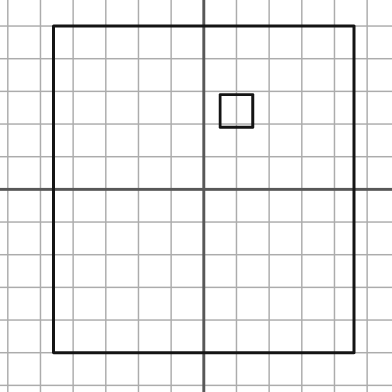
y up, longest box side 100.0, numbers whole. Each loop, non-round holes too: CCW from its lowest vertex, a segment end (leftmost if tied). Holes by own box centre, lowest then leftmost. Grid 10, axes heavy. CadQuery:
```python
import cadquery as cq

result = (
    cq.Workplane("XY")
    .moveTo(-46.0, -50.0)
    .lineTo(46.0, -50.0)
    .lineTo(46.0, 50.0)
    .lineTo(-46.0, 50.0)
    .close()
    .moveTo(5.0, 19.0)
    .lineTo(15.0, 19.0)
    .lineTo(15.0, 29.0)
    .lineTo(5.0, 29.0)
    .close()
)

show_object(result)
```